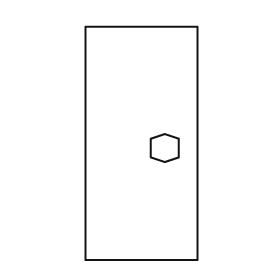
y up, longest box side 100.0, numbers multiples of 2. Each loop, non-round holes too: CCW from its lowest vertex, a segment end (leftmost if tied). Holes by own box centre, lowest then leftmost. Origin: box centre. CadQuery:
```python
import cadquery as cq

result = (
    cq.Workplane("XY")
    .moveTo(-24.0, -50.0)
    .lineTo(24.0, -50.0)
    .lineTo(24.0, 50.0)
    .lineTo(-24.0, 50.0)
    .close()
    .moveTo(10.0, -8.0)
    .lineTo(16.0, -6.0)
    .lineTo(16.0, 2.0)
    .lineTo(10.0, 4.0)
    .lineTo(4.0, 2.0)
    .lineTo(4.0, -6.0)
    .close()
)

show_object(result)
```